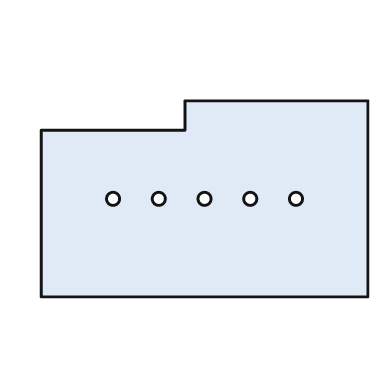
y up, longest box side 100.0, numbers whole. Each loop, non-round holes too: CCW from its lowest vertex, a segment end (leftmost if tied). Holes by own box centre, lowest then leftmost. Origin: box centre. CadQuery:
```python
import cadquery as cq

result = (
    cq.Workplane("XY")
    .moveTo(-50.0, -30.0)
    .lineTo(50.0, -30.0)
    .lineTo(50.0, 30.0)
    .lineTo(-6.0, 30.0)
    .lineTo(-6.0, 21.0)
    .lineTo(-50.0, 21.0)
    .close()
    .moveTo(-28.0, 0.0)
    .circle(2.0)
    .moveTo(-14.0, 0.0)
    .circle(2.0)
    .moveTo(0.0, 0.0)
    .circle(2.0)
    .moveTo(14.0, 0.0)
    .circle(2.0)
    .moveTo(28.0, 0.0)
    .circle(2.0)
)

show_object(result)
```